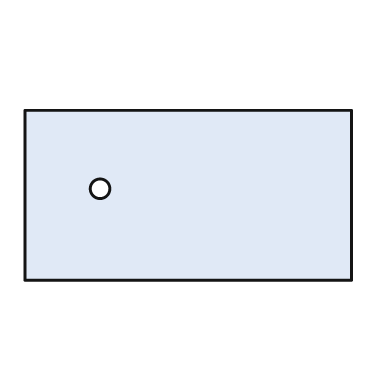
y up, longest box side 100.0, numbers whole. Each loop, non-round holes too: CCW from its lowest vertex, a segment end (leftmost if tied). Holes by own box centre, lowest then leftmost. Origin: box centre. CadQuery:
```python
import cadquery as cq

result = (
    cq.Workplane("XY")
    .moveTo(-50.0, -26.0)
    .lineTo(50.0, -26.0)
    .lineTo(50.0, 26.0)
    .lineTo(-50.0, 26.0)
    .close()
    .moveTo(-27.0, 2.0)
    .circle(3.0)
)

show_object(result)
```